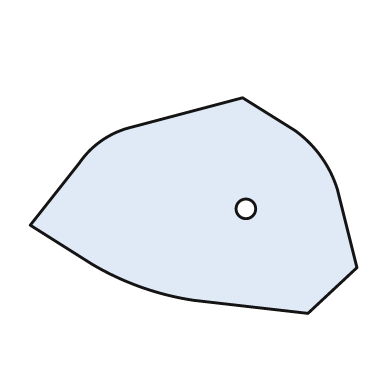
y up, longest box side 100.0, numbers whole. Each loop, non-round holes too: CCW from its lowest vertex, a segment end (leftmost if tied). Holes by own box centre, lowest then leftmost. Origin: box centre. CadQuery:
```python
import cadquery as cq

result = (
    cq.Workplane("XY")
    .moveTo(35.0, -33.0)
    .lineTo(50.0, -19.0)
    .lineTo(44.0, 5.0)
    .threePointArc((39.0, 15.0), (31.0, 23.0))
    .lineTo(15.0, 33.0)
    .lineTo(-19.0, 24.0)
    .threePointArc((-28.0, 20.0), (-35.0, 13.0))
    .lineTo(-50.0, -6.0)
    .lineTo(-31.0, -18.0)
    .threePointArc((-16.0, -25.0), (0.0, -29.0))
    .close()
    .moveTo(16.0, -1.0)
    .circle(3.0)
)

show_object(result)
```